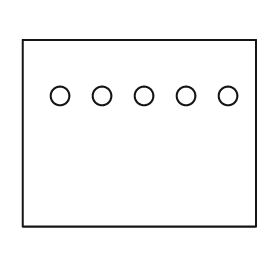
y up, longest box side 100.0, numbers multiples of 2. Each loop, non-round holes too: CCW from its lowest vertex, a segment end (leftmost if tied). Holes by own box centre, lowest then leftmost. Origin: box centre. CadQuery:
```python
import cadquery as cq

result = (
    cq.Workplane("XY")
    .moveTo(-50.0, -40.0)
    .lineTo(50.0, -40.0)
    .lineTo(50.0, 40.0)
    .lineTo(-50.0, 40.0)
    .close()
    .moveTo(-34.0, 16.0)
    .circle(4.0)
    .moveTo(-16.0, 16.0)
    .circle(4.0)
    .moveTo(2.0, 16.0)
    .circle(4.0)
    .moveTo(20.0, 16.0)
    .circle(4.0)
    .moveTo(38.0, 16.0)
    .circle(4.0)
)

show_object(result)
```